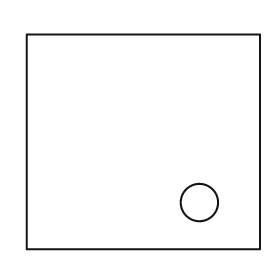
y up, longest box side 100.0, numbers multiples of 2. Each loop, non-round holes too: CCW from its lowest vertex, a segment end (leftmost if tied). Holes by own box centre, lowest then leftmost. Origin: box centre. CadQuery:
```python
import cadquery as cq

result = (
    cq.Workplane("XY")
    .moveTo(-50.0, -46.0)
    .lineTo(50.0, -46.0)
    .lineTo(50.0, 46.0)
    .lineTo(-50.0, 46.0)
    .close()
    .moveTo(24.0, -26.0)
    .circle(8.0)
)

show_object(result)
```